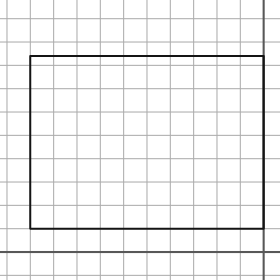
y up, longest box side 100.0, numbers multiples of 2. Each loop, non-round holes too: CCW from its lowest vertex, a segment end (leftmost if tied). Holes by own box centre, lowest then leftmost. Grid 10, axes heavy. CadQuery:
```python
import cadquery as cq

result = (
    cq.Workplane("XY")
    .moveTo(-100.0, 10.0)
    .lineTo(0.0, 10.0)
    .lineTo(0.0, 84.0)
    .lineTo(-100.0, 84.0)
    .close()
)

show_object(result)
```